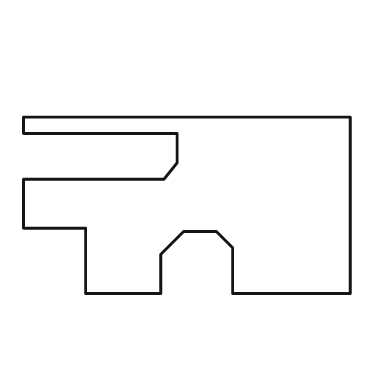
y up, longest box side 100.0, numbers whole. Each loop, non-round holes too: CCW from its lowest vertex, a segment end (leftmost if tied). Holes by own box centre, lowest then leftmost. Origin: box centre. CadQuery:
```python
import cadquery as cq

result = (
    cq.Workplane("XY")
    .moveTo(-31.0, -27.0)
    .lineTo(-8.0, -27.0)
    .lineTo(-8.0, -15.0)
    .lineTo(-1.0, -8.0)
    .lineTo(9.0, -8.0)
    .lineTo(14.0, -13.0)
    .lineTo(14.0, -27.0)
    .lineTo(50.0, -27.0)
    .lineTo(50.0, 27.0)
    .lineTo(-50.0, 27.0)
    .lineTo(-50.0, 22.0)
    .lineTo(-3.0, 22.0)
    .lineTo(-3.0, 13.0)
    .lineTo(-7.0, 8.0)
    .lineTo(-50.0, 8.0)
    .lineTo(-50.0, -7.0)
    .lineTo(-31.0, -7.0)
    .close()
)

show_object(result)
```